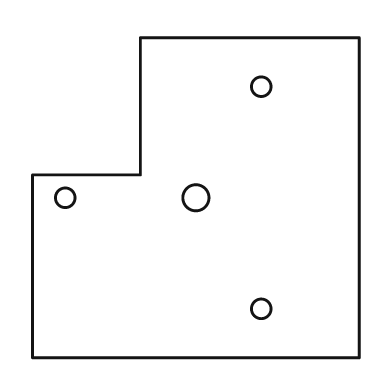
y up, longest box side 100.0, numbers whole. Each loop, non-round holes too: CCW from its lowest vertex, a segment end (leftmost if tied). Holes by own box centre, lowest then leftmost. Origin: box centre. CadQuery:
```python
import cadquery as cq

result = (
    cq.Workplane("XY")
    .moveTo(-50.0, -49.0)
    .lineTo(50.0, -49.0)
    .lineTo(50.0, 49.0)
    .lineTo(-17.0, 49.0)
    .lineTo(-17.0, 7.0)
    .lineTo(-50.0, 7.0)
    .close()
    .moveTo(20.0, -34.0)
    .circle(3.0)
    .moveTo(-40.0, 0.0)
    .circle(3.0)
    .moveTo(0.0, 0.0)
    .circle(4.0)
    .moveTo(20.0, 34.0)
    .circle(3.0)
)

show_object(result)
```